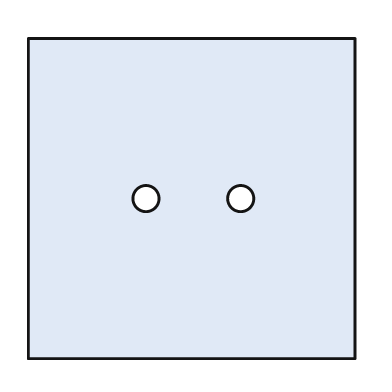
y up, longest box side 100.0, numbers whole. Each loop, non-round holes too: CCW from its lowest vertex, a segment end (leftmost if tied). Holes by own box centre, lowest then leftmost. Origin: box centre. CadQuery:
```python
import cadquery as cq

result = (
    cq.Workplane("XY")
    .moveTo(-50.0, -49.0)
    .lineTo(50.0, -49.0)
    .lineTo(50.0, 49.0)
    .lineTo(-50.0, 49.0)
    .close()
    .moveTo(-14.0, 0.0)
    .circle(4.0)
    .moveTo(15.0, 0.0)
    .circle(4.0)
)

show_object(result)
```